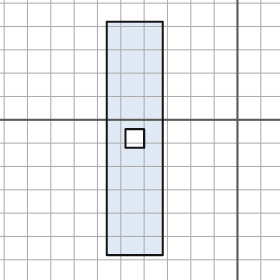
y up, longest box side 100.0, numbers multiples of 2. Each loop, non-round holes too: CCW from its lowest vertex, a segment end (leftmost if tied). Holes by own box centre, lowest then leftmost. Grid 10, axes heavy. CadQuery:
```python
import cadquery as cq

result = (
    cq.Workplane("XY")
    .moveTo(-56.0, -58.0)
    .lineTo(-32.0, -58.0)
    .lineTo(-32.0, 42.0)
    .lineTo(-56.0, 42.0)
    .close()
    .moveTo(-48.0, -12.0)
    .lineTo(-40.0, -12.0)
    .lineTo(-40.0, -4.0)
    .lineTo(-48.0, -4.0)
    .close()
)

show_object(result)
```